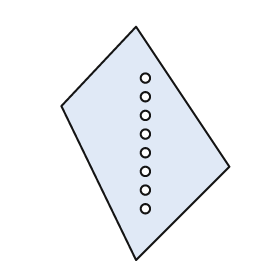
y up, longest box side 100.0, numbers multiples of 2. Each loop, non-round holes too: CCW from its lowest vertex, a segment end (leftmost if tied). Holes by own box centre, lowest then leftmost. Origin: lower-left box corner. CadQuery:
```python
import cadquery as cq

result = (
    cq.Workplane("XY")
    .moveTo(32.0, 0.0)
    .lineTo(72.0, 40.0)
    .lineTo(32.0, 100.0)
    .lineTo(0.0, 66.0)
    .close()
    .moveTo(36.0, 22.0)
    .circle(2.0)
    .moveTo(36.0, 30.0)
    .circle(2.0)
    .moveTo(36.0, 38.0)
    .circle(2.0)
    .moveTo(36.0, 46.0)
    .circle(2.0)
    .moveTo(36.0, 54.0)
    .circle(2.0)
    .moveTo(36.0, 62.0)
    .circle(2.0)
    .moveTo(36.0, 70.0)
    .circle(2.0)
    .moveTo(36.0, 78.0)
    .circle(2.0)
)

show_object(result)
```